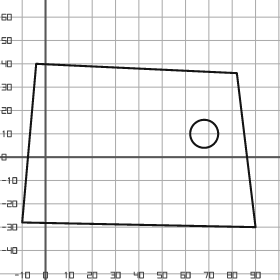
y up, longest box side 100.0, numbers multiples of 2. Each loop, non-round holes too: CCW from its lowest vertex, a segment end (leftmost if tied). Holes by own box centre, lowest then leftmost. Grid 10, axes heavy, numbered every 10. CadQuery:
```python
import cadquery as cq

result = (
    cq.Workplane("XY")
    .moveTo(90.0, -30.0)
    .lineTo(82.0, 36.0)
    .lineTo(-4.0, 40.0)
    .lineTo(-10.0, -28.0)
    .close()
    .moveTo(68.0, 10.0)
    .circle(6.0)
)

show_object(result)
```